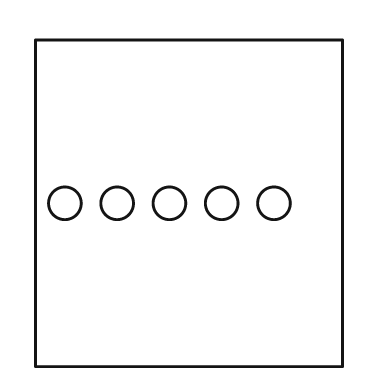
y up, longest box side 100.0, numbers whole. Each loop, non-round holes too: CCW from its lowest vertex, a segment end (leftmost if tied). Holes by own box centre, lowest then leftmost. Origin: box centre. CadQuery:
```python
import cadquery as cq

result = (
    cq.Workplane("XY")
    .moveTo(-47.0, -50.0)
    .lineTo(47.0, -50.0)
    .lineTo(47.0, 50.0)
    .lineTo(-47.0, 50.0)
    .close()
    .moveTo(-38.0, 0.0)
    .circle(5.0)
    .moveTo(-22.0, 0.0)
    .circle(5.0)
    .moveTo(-6.0, 0.0)
    .circle(5.0)
    .moveTo(10.0, 0.0)
    .circle(5.0)
    .moveTo(26.0, 0.0)
    .circle(5.0)
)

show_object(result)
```